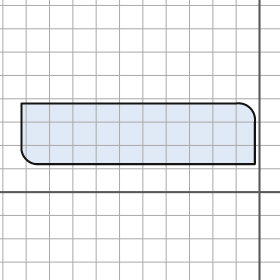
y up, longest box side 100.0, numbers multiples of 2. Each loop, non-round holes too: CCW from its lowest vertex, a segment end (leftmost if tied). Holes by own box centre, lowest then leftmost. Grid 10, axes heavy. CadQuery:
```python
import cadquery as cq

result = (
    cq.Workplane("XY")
    .moveTo(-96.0, 12.0)
    .lineTo(-2.0, 12.0)
    .lineTo(-2.0, 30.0)
    .threePointArc((-4.0, 36.0), (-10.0, 38.0))
    .lineTo(-102.0, 38.0)
    .lineTo(-102.0, 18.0)
    .threePointArc((-100.0, 14.0), (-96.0, 12.0))
    .close()
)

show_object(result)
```